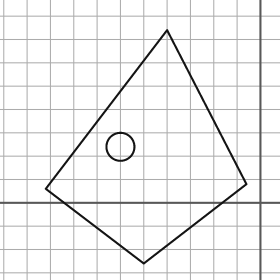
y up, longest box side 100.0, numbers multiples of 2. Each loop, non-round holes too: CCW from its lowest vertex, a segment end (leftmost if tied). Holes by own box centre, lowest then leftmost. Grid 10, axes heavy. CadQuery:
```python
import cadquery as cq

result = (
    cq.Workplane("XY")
    .moveTo(-50.0, -26.0)
    .lineTo(-6.0, 8.0)
    .lineTo(-40.0, 74.0)
    .lineTo(-92.0, 6.0)
    .close()
    .moveTo(-60.0, 24.0)
    .circle(6.0)
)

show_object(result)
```